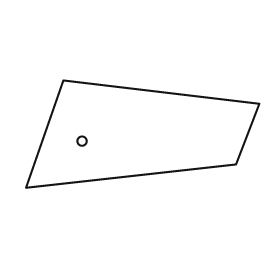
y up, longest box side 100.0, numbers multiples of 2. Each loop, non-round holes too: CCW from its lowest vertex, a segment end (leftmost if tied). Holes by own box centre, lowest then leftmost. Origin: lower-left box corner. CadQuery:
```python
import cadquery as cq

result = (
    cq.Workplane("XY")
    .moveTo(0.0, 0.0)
    .lineTo(90.0, 10.0)
    .lineTo(100.0, 36.0)
    .lineTo(16.0, 46.0)
    .close()
    .moveTo(24.0, 20.0)
    .circle(2.0)
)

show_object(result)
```